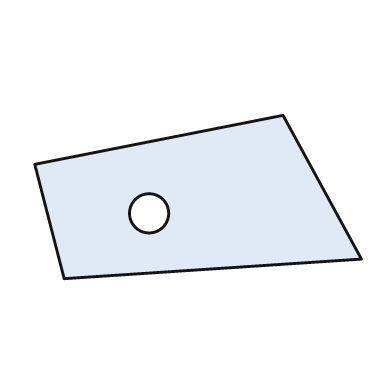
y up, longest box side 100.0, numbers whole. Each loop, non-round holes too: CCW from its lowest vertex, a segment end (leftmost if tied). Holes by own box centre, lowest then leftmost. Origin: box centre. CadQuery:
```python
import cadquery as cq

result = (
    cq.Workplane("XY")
    .moveTo(-41.0, -25.0)
    .lineTo(50.0, -19.0)
    .lineTo(26.0, 25.0)
    .lineTo(-50.0, 10.0)
    .close()
    .moveTo(-15.0, -5.0)
    .circle(6.0)
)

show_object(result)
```